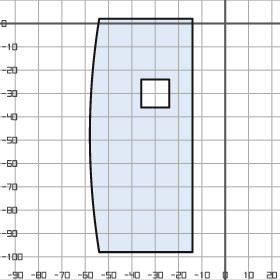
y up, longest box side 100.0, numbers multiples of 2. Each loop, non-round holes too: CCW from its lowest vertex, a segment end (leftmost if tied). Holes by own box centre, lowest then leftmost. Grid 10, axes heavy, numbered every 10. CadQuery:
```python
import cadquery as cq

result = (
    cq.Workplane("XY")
    .moveTo(-54.0, -98.0)
    .lineTo(-14.0, -98.0)
    .lineTo(-14.0, 2.0)
    .lineTo(-54.0, 2.0)
    .threePointArc((-58.0, -48.0), (-54.0, -98.0))
    .close()
    .moveTo(-36.0, -36.0)
    .lineTo(-24.0, -36.0)
    .lineTo(-24.0, -24.0)
    .lineTo(-36.0, -24.0)
    .close()
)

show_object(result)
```